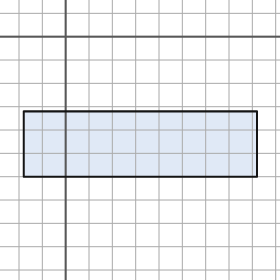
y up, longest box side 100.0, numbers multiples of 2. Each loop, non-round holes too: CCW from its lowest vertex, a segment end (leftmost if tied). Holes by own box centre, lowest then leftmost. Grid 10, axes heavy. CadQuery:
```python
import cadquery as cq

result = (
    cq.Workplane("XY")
    .moveTo(-18.0, -60.0)
    .lineTo(82.0, -60.0)
    .lineTo(82.0, -32.0)
    .lineTo(-18.0, -32.0)
    .close()
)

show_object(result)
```